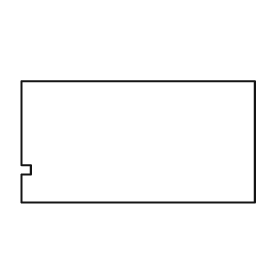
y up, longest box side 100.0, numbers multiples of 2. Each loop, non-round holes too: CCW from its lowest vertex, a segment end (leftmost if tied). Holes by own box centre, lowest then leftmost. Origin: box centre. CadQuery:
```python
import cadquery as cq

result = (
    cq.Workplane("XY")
    .moveTo(-50.0, -26.0)
    .lineTo(50.0, -26.0)
    .lineTo(50.0, 26.0)
    .lineTo(-50.0, 26.0)
    .lineTo(-50.0, -10.0)
    .lineTo(-46.0, -10.0)
    .lineTo(-46.0, -14.0)
    .lineTo(-50.0, -14.0)
    .close()
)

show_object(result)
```